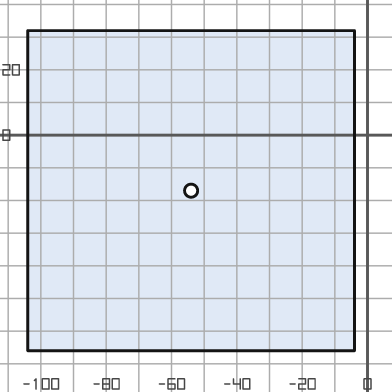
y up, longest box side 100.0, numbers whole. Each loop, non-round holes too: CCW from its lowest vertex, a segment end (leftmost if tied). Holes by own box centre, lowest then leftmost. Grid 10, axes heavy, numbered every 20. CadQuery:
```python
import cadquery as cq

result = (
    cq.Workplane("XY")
    .moveTo(-104.0, -66.0)
    .lineTo(-4.0, -66.0)
    .lineTo(-4.0, 32.0)
    .lineTo(-104.0, 32.0)
    .close()
    .moveTo(-54.0, -17.0)
    .circle(2.0)
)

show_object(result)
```